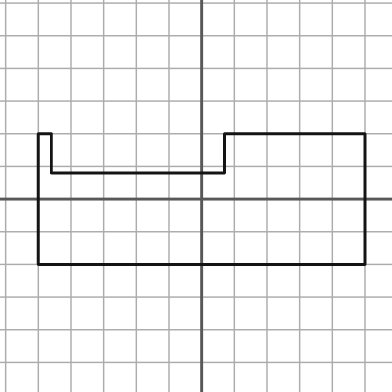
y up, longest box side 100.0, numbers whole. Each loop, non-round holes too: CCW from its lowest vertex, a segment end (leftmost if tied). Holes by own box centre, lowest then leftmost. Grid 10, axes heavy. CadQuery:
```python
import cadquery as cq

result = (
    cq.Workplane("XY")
    .moveTo(-50.0, -20.0)
    .lineTo(50.0, -20.0)
    .lineTo(50.0, 20.0)
    .lineTo(7.0, 20.0)
    .lineTo(7.0, 8.0)
    .lineTo(-46.0, 8.0)
    .lineTo(-46.0, 20.0)
    .lineTo(-50.0, 20.0)
    .close()
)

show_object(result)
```